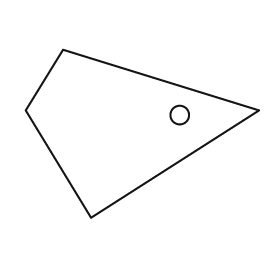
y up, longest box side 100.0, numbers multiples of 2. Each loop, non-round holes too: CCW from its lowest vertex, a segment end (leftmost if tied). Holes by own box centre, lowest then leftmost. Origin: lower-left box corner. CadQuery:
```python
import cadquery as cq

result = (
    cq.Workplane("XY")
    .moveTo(28.0, 0.0)
    .lineTo(100.0, 46.0)
    .lineTo(16.0, 72.0)
    .lineTo(0.0, 46.0)
    .close()
    .moveTo(66.0, 44.0)
    .circle(4.0)
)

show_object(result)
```